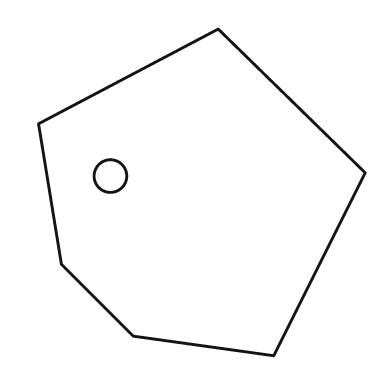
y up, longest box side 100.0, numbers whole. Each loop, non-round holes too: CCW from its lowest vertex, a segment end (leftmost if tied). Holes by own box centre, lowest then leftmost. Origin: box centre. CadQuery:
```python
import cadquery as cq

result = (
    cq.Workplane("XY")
    .moveTo(22.0, -50.0)
    .lineTo(50.0, 6.0)
    .lineTo(5.0, 50.0)
    .lineTo(-50.0, 21.0)
    .lineTo(-43.0, -22.0)
    .lineTo(-21.0, -44.0)
    .close()
    .moveTo(-28.0, 5.0)
    .circle(5.0)
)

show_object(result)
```